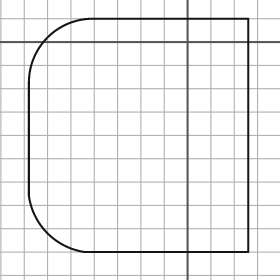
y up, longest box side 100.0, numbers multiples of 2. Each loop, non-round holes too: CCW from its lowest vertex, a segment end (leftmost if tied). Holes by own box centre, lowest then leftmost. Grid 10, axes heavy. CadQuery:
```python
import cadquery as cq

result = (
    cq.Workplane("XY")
    .moveTo(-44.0, -90.0)
    .lineTo(26.0, -90.0)
    .lineTo(26.0, 10.0)
    .lineTo(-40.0, 10.0)
    .threePointArc((-60.0, 2.0), (-68.0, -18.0))
    .lineTo(-68.0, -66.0)
    .threePointArc((-60.0, -82.0), (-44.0, -90.0))
    .close()
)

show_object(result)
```